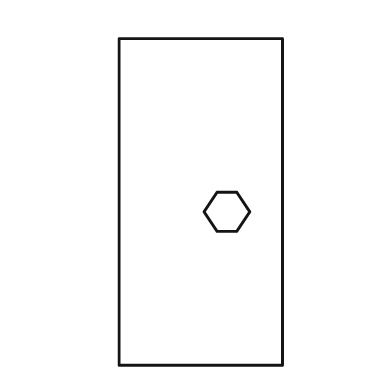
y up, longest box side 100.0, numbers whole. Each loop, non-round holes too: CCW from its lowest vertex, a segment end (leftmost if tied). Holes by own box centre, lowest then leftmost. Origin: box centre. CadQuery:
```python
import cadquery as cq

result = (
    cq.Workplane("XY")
    .moveTo(-25.0, -50.0)
    .lineTo(25.0, -50.0)
    .lineTo(25.0, 50.0)
    .lineTo(-25.0, 50.0)
    .close()
    .moveTo(5.0, -9.0)
    .lineTo(11.0, -9.0)
    .lineTo(15.0, -3.0)
    .lineTo(11.0, 3.0)
    .lineTo(5.0, 3.0)
    .lineTo(1.0, -3.0)
    .close()
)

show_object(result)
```